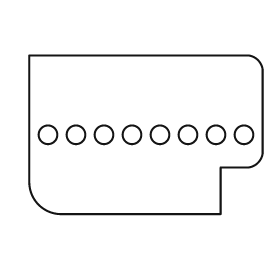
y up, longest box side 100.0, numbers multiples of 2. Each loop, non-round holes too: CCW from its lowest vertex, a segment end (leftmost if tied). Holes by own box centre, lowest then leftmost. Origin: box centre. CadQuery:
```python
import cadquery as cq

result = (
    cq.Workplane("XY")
    .moveTo(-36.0, -34.0)
    .lineTo(32.0, -34.0)
    .lineTo(32.0, -14.0)
    .lineTo(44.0, -14.0)
    .threePointArc((48.0, -12.0), (50.0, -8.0))
    .lineTo(50.0, 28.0)
    .threePointArc((48.0, 32.0), (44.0, 34.0))
    .lineTo(-50.0, 34.0)
    .lineTo(-50.0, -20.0)
    .threePointArc((-46.0, -30.0), (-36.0, -34.0))
    .close()
    .moveTo(-42.0, 0.0)
    .circle(4.0)
    .moveTo(-30.0, 0.0)
    .circle(4.0)
    .moveTo(-18.0, 0.0)
    .circle(4.0)
    .moveTo(-6.0, 0.0)
    .circle(4.0)
    .moveTo(6.0, 0.0)
    .circle(4.0)
    .moveTo(18.0, 0.0)
    .circle(4.0)
    .moveTo(30.0, 0.0)
    .circle(4.0)
    .moveTo(42.0, 0.0)
    .circle(4.0)
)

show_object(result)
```